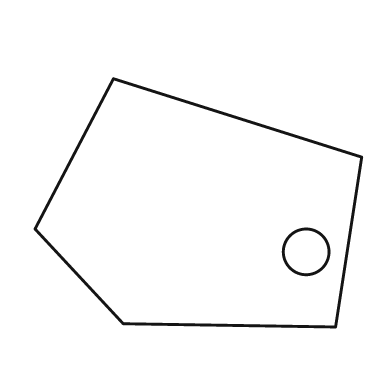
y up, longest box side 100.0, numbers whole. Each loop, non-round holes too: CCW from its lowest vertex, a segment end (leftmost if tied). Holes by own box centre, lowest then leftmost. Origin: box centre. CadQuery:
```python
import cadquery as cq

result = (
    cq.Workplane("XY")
    .moveTo(42.0, -38.0)
    .lineTo(50.0, 14.0)
    .lineTo(-26.0, 38.0)
    .lineTo(-50.0, -8.0)
    .lineTo(-23.0, -37.0)
    .close()
    .moveTo(33.0, -15.0)
    .circle(7.0)
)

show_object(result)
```